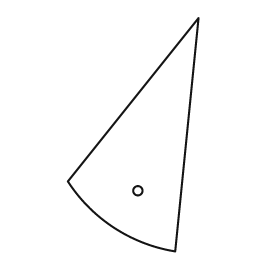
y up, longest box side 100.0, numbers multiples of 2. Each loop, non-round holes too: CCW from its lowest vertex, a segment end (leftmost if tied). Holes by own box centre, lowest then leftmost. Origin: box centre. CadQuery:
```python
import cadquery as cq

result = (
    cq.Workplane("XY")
    .moveTo(18.0, -50.0)
    .lineTo(28.0, 50.0)
    .lineTo(-28.0, -20.0)
    .threePointArc((-8.0, -40.0), (18.0, -50.0))
    .close()
    .moveTo(2.0, -24.0)
    .circle(2.0)
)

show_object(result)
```